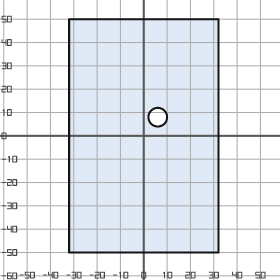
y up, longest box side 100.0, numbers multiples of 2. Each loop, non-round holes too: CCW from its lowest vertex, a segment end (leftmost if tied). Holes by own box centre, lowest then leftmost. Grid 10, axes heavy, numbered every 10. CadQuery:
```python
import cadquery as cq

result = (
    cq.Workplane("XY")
    .moveTo(-32.0, -50.0)
    .lineTo(32.0, -50.0)
    .lineTo(32.0, 50.0)
    .lineTo(-32.0, 50.0)
    .close()
    .moveTo(6.0, 8.0)
    .circle(4.0)
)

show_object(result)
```